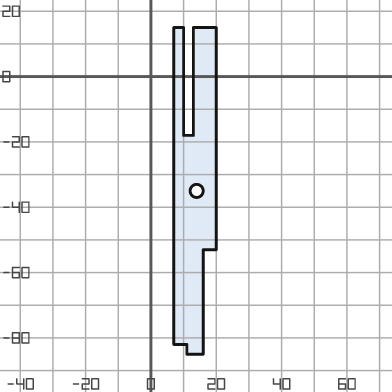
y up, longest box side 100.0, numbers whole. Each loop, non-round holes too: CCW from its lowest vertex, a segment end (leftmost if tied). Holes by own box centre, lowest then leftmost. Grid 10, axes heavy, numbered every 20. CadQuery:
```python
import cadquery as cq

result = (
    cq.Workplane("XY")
    .moveTo(11.0, -85.0)
    .lineTo(16.0, -85.0)
    .lineTo(16.0, -53.0)
    .lineTo(20.0, -53.0)
    .lineTo(20.0, 15.0)
    .lineTo(13.0, 15.0)
    .lineTo(13.0, -18.0)
    .lineTo(10.0, -18.0)
    .lineTo(10.0, 15.0)
    .lineTo(7.0, 15.0)
    .lineTo(7.0, -82.0)
    .lineTo(11.0, -82.0)
    .close()
    .moveTo(14.0, -35.0)
    .circle(2.0)
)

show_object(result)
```